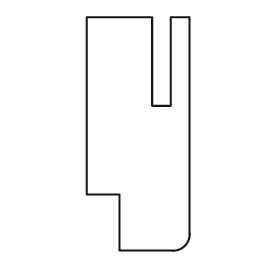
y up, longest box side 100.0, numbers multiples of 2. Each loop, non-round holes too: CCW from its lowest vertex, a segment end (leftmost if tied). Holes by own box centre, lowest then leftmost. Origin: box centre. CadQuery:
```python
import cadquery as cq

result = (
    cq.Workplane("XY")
    .moveTo(-8.0, -50.0)
    .lineTo(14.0, -50.0)
    .threePointArc((20.0, -48.0), (22.0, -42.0))
    .lineTo(22.0, 50.0)
    .lineTo(14.0, 50.0)
    .lineTo(14.0, 12.0)
    .lineTo(6.0, 12.0)
    .lineTo(6.0, 50.0)
    .lineTo(-22.0, 50.0)
    .lineTo(-22.0, -26.0)
    .lineTo(-8.0, -26.0)
    .close()
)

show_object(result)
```